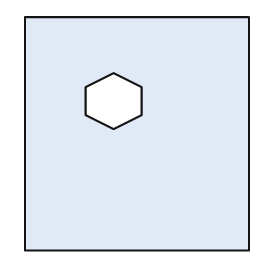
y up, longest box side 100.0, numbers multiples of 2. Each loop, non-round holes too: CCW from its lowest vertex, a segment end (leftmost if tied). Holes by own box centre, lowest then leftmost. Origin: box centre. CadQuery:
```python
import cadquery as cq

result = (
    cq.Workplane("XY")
    .moveTo(-48.0, -50.0)
    .lineTo(48.0, -50.0)
    .lineTo(48.0, 50.0)
    .lineTo(-48.0, 50.0)
    .close()
    .moveTo(-10.0, 2.0)
    .lineTo(2.0, 8.0)
    .lineTo(2.0, 20.0)
    .lineTo(-10.0, 26.0)
    .lineTo(-22.0, 20.0)
    .lineTo(-22.0, 8.0)
    .close()
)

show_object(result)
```